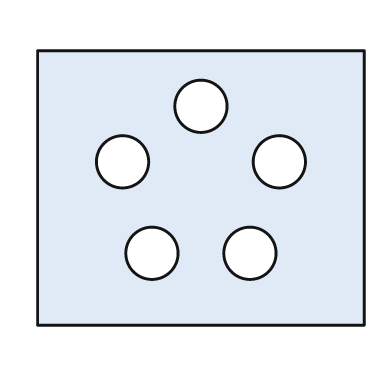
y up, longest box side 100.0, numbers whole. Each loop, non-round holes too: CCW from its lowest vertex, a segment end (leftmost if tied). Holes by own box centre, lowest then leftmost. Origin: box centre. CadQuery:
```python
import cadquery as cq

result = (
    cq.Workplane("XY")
    .moveTo(-50.0, -42.0)
    .lineTo(50.0, -42.0)
    .lineTo(50.0, 42.0)
    .lineTo(-50.0, 42.0)
    .close()
    .moveTo(-15.0, -20.0)
    .circle(8.0)
    .moveTo(15.0, -20.0)
    .circle(8.0)
    .moveTo(-24.0, 8.0)
    .circle(8.0)
    .moveTo(24.0, 8.0)
    .circle(8.0)
    .moveTo(0.0, 25.0)
    .circle(8.0)
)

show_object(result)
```